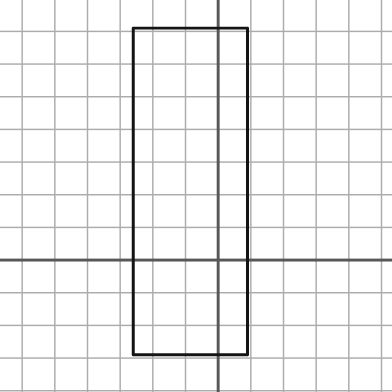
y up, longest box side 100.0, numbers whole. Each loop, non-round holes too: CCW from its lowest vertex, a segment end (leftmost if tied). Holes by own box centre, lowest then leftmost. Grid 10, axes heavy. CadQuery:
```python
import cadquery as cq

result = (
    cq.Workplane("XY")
    .moveTo(-26.0, -29.0)
    .lineTo(9.0, -29.0)
    .lineTo(9.0, 71.0)
    .lineTo(-26.0, 71.0)
    .close()
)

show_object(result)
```